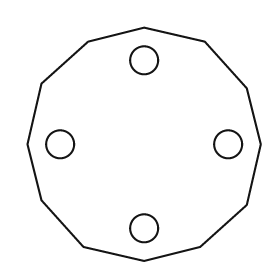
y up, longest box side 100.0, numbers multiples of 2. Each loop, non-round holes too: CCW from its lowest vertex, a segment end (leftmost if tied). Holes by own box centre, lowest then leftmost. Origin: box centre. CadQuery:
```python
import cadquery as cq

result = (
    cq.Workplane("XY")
    .moveTo(0.0, -50.0)
    .lineTo(24.0, -44.0)
    .lineTo(44.0, -26.0)
    .lineTo(50.0, 0.0)
    .lineTo(44.0, 24.0)
    .lineTo(26.0, 44.0)
    .lineTo(0.0, 50.0)
    .lineTo(-24.0, 44.0)
    .lineTo(-44.0, 26.0)
    .lineTo(-50.0, 0.0)
    .lineTo(-44.0, -24.0)
    .lineTo(-26.0, -44.0)
    .close()
    .moveTo(0.0, -36.0)
    .circle(6.0)
    .moveTo(-36.0, 0.0)
    .circle(6.0)
    .moveTo(36.0, 0.0)
    .circle(6.0)
    .moveTo(0.0, 36.0)
    .circle(6.0)
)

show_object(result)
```